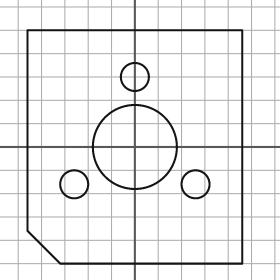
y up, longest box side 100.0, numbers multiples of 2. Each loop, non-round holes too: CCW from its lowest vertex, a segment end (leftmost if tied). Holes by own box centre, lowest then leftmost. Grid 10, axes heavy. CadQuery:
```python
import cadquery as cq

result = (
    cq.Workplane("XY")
    .moveTo(-32.0, -50.0)
    .lineTo(46.0, -50.0)
    .lineTo(46.0, 50.0)
    .lineTo(-46.0, 50.0)
    .lineTo(-46.0, -36.0)
    .close()
    .moveTo(-26.0, -16.0)
    .circle(6.0)
    .moveTo(26.0, -16.0)
    .circle(6.0)
    .moveTo(0.0, 0.0)
    .circle(18.0)
    .moveTo(0.0, 30.0)
    .circle(6.0)
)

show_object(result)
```